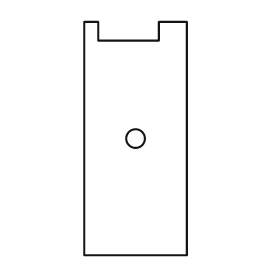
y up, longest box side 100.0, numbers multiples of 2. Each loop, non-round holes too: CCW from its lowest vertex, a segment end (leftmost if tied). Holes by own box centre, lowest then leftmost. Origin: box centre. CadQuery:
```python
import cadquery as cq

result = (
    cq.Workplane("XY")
    .moveTo(-22.0, -50.0)
    .lineTo(22.0, -50.0)
    .lineTo(22.0, 50.0)
    .lineTo(10.0, 50.0)
    .lineTo(10.0, 42.0)
    .lineTo(-16.0, 42.0)
    .lineTo(-16.0, 50.0)
    .lineTo(-22.0, 50.0)
    .close()
    .moveTo(0.0, 0.0)
    .circle(4.0)
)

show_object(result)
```